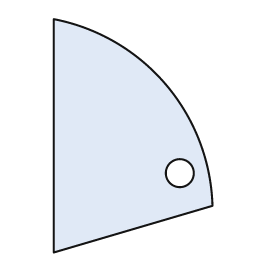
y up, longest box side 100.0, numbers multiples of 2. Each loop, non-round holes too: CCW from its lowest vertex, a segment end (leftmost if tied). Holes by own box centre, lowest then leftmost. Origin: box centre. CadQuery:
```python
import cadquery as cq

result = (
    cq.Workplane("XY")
    .moveTo(-34.0, -50.0)
    .lineTo(34.0, -30.0)
    .threePointArc((14.0, 22.0), (-34.0, 50.0))
    .close()
    .moveTo(20.0, -16.0)
    .circle(6.0)
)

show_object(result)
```